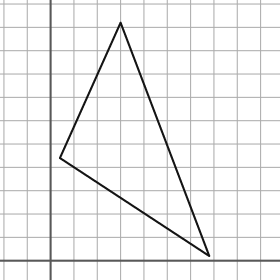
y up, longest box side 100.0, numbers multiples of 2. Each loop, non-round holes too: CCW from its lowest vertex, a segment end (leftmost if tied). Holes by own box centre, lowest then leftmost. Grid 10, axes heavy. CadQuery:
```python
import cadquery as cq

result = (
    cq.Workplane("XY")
    .moveTo(68.0, 2.0)
    .lineTo(30.0, 102.0)
    .lineTo(4.0, 44.0)
    .close()
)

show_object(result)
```